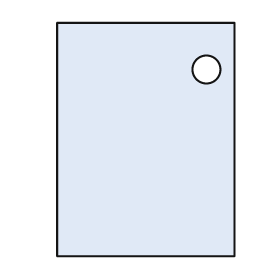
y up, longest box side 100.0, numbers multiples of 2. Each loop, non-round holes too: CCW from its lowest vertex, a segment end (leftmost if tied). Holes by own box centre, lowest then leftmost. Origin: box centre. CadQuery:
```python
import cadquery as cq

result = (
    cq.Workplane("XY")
    .moveTo(-38.0, -50.0)
    .lineTo(38.0, -50.0)
    .lineTo(38.0, 50.0)
    .lineTo(-38.0, 50.0)
    .close()
    .moveTo(26.0, 30.0)
    .circle(6.0)
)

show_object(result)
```